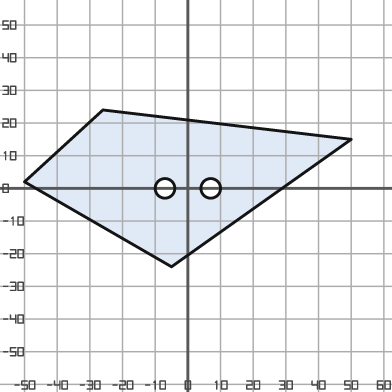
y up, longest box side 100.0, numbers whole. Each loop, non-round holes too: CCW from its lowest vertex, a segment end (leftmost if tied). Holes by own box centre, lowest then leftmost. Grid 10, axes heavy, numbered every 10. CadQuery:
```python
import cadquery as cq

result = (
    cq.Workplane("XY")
    .moveTo(-5.0, -24.0)
    .lineTo(50.0, 15.0)
    .lineTo(-26.0, 24.0)
    .lineTo(-50.0, 2.0)
    .close()
    .moveTo(-7.0, 0.0)
    .circle(3.0)
    .moveTo(7.0, 0.0)
    .circle(3.0)
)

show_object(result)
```